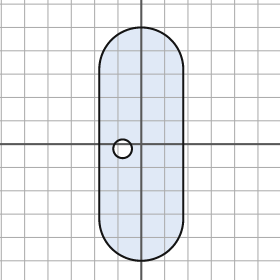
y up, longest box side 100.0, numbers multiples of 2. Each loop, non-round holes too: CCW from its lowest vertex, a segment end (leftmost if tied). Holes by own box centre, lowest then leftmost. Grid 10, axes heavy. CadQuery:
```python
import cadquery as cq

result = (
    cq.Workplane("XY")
    .moveTo(-18.0, -32.0)
    .threePointArc((0.0, -50.0), (18.0, -32.0))
    .lineTo(18.0, 32.0)
    .threePointArc((0.0, 50.0), (-18.0, 32.0))
    .close()
    .moveTo(-8.0, -2.0)
    .circle(4.0)
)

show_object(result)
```